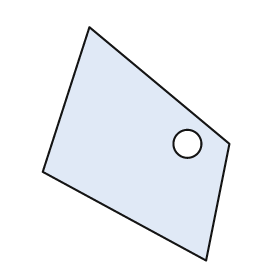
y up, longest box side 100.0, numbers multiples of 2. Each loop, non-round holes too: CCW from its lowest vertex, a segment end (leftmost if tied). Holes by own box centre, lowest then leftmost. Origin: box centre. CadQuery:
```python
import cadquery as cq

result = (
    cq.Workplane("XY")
    .moveTo(30.0, -50.0)
    .lineTo(40.0, 0.0)
    .lineTo(-20.0, 50.0)
    .lineTo(-40.0, -12.0)
    .close()
    .moveTo(22.0, 0.0)
    .circle(6.0)
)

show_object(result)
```